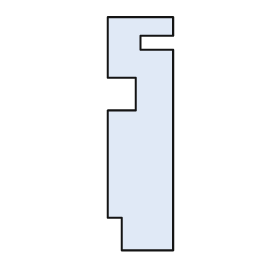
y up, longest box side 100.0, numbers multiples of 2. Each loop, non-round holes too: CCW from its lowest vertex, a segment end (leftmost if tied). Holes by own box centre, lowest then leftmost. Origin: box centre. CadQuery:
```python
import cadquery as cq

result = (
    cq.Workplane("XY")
    .moveTo(-8.0, -50.0)
    .lineTo(14.0, -50.0)
    .lineTo(14.0, 36.0)
    .lineTo(0.0, 36.0)
    .lineTo(0.0, 42.0)
    .lineTo(14.0, 42.0)
    .lineTo(14.0, 50.0)
    .lineTo(-14.0, 50.0)
    .lineTo(-14.0, 24.0)
    .lineTo(-2.0, 24.0)
    .lineTo(-2.0, 10.0)
    .lineTo(-14.0, 10.0)
    .lineTo(-14.0, -36.0)
    .lineTo(-8.0, -36.0)
    .close()
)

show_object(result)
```